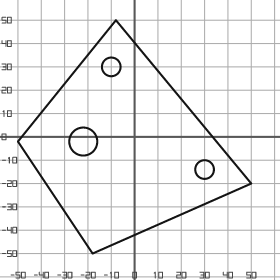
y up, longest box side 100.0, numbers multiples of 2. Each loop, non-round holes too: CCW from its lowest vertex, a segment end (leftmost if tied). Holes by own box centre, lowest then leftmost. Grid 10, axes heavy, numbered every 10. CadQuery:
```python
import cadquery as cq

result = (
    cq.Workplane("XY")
    .moveTo(-18.0, -50.0)
    .lineTo(50.0, -20.0)
    .lineTo(-8.0, 50.0)
    .lineTo(-50.0, -2.0)
    .close()
    .moveTo(30.0, -14.0)
    .circle(4.0)
    .moveTo(-22.0, -2.0)
    .circle(6.0)
    .moveTo(-10.0, 30.0)
    .circle(4.0)
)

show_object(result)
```